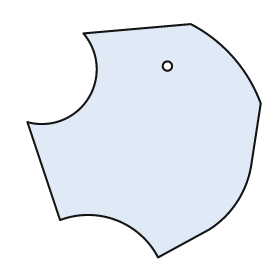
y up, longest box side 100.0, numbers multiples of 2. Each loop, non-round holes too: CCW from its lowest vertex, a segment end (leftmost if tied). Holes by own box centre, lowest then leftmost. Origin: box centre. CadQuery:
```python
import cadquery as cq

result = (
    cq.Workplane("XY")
    .moveTo(6.0, -50.0)
    .lineTo(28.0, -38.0)
    .threePointArc((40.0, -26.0), (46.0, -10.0))
    .lineTo(50.0, 16.0)
    .threePointArc((38.0, 36.0), (20.0, 50.0))
    .lineTo(-26.0, 46.0)
    .threePointArc((-24.0, 18.0), (-50.0, 8.0))
    .lineTo(-36.0, -34.0)
    .threePointArc((-12.0, -34.0), (6.0, -50.0))
    .close()
    .moveTo(10.0, 32.0)
    .circle(2.0)
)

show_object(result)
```